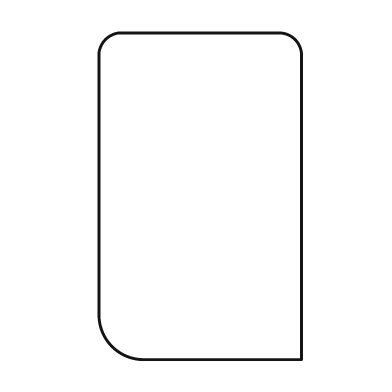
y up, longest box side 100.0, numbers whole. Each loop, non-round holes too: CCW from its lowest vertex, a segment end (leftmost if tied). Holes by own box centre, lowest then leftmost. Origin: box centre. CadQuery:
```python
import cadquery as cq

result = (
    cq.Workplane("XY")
    .moveTo(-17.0, -50.0)
    .lineTo(31.0, -50.0)
    .lineTo(31.0, 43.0)
    .threePointArc((29.0, 48.0), (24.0, 50.0))
    .lineTo(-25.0, 50.0)
    .threePointArc((-29.0, 48.0), (-31.0, 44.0))
    .lineTo(-31.0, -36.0)
    .threePointArc((-27.0, -46.0), (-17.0, -50.0))
    .close()
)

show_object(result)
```